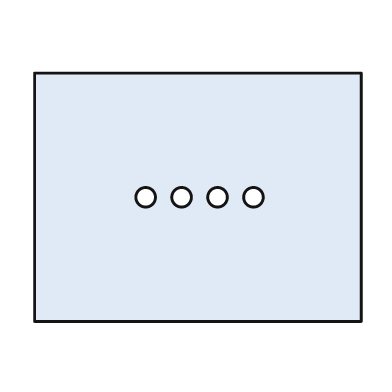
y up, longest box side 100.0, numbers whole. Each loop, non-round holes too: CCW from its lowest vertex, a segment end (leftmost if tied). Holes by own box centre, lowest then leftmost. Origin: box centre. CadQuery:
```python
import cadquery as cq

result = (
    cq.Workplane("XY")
    .moveTo(-50.0, -38.0)
    .lineTo(50.0, -38.0)
    .lineTo(50.0, 38.0)
    .lineTo(-50.0, 38.0)
    .close()
    .moveTo(-16.0, 0.0)
    .circle(3.0)
    .moveTo(-5.0, 0.0)
    .circle(3.0)
    .moveTo(6.0, 0.0)
    .circle(3.0)
    .moveTo(17.0, 0.0)
    .circle(3.0)
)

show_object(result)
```